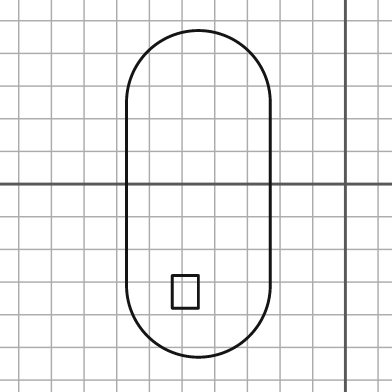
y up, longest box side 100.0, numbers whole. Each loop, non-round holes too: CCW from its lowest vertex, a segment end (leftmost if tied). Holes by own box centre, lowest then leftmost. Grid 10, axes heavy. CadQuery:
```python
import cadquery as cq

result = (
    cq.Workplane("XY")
    .moveTo(-67.0, -31.0)
    .threePointArc((-45.0, -53.0), (-23.0, -31.0))
    .lineTo(-23.0, 25.0)
    .threePointArc((-45.0, 47.0), (-67.0, 25.0))
    .close()
    .moveTo(-53.0, -38.0)
    .lineTo(-45.0, -38.0)
    .lineTo(-45.0, -28.0)
    .lineTo(-53.0, -28.0)
    .close()
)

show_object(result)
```